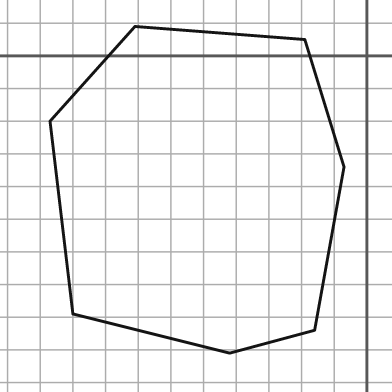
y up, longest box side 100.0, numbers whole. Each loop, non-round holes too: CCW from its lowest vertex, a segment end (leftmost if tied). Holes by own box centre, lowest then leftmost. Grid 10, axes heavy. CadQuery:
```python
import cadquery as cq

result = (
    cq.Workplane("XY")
    .moveTo(-42.0, -91.0)
    .lineTo(-16.0, -84.0)
    .lineTo(-7.0, -34.0)
    .lineTo(-19.0, 5.0)
    .lineTo(-71.0, 9.0)
    .lineTo(-97.0, -20.0)
    .lineTo(-90.0, -79.0)
    .close()
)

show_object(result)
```